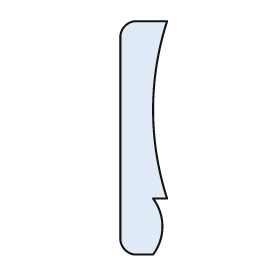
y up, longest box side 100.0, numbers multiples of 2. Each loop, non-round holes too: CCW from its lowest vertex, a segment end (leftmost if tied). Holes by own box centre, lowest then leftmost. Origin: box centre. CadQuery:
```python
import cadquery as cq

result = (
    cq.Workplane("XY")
    .moveTo(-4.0, -50.0)
    .lineTo(4.0, -50.0)
    .threePointArc((8.0, -38.0), (4.0, -26.0))
    .lineTo(10.0, -26.0)
    .threePointArc((4.0, 12.0), (10.0, 50.0))
    .lineTo(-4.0, 50.0)
    .threePointArc((-8.0, 48.0), (-10.0, 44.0))
    .lineTo(-10.0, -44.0)
    .threePointArc((-8.0, -48.0), (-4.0, -50.0))
    .close()
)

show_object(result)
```